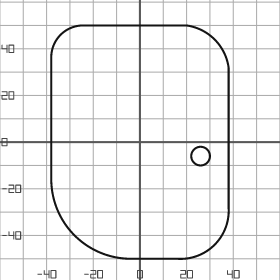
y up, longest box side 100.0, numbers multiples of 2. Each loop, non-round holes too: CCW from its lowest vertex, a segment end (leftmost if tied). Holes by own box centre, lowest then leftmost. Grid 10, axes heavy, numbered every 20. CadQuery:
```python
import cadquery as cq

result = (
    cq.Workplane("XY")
    .moveTo(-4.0, -50.0)
    .lineTo(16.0, -50.0)
    .threePointArc((32.0, -44.0), (38.0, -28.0))
    .lineTo(38.0, 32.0)
    .threePointArc((32.0, 44.0), (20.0, 50.0))
    .lineTo(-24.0, 50.0)
    .threePointArc((-34.0, 46.0), (-38.0, 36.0))
    .lineTo(-38.0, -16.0)
    .threePointArc((-28.0, -40.0), (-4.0, -50.0))
    .close()
    .moveTo(26.0, -6.0)
    .circle(4.0)
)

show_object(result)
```